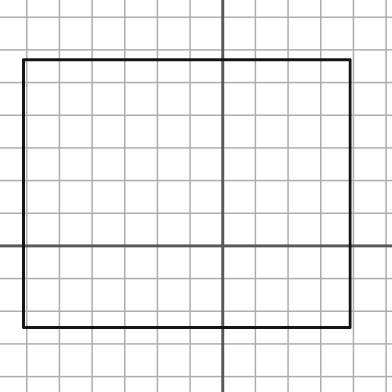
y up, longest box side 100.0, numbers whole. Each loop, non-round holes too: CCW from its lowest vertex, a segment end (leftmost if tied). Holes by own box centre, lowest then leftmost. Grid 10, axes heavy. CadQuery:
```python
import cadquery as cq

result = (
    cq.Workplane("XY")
    .moveTo(-61.0, -25.0)
    .lineTo(39.0, -25.0)
    .lineTo(39.0, 57.0)
    .lineTo(-61.0, 57.0)
    .close()
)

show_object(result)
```